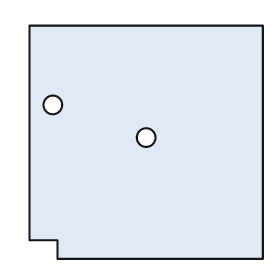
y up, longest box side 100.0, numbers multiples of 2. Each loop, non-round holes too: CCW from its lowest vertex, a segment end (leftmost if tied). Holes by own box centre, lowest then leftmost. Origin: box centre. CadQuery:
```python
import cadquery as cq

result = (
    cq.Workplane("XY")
    .moveTo(-38.0, -50.0)
    .lineTo(50.0, -50.0)
    .lineTo(50.0, 50.0)
    .lineTo(-50.0, 50.0)
    .lineTo(-50.0, -42.0)
    .lineTo(-38.0, -42.0)
    .close()
    .moveTo(0.0, 2.0)
    .circle(4.0)
    .moveTo(-40.0, 16.0)
    .circle(4.0)
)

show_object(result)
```